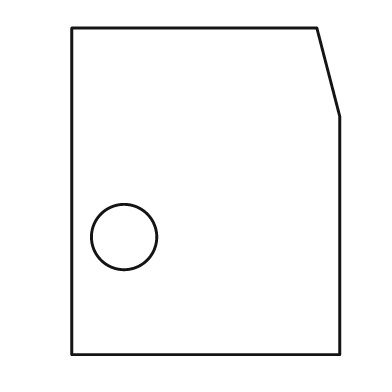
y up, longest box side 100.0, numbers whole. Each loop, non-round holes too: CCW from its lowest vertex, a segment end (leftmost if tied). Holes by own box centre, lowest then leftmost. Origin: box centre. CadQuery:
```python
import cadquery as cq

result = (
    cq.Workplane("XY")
    .moveTo(-41.0, -50.0)
    .lineTo(41.0, -50.0)
    .lineTo(41.0, 23.0)
    .lineTo(34.0, 50.0)
    .lineTo(-41.0, 50.0)
    .close()
    .moveTo(-25.0, -14.0)
    .circle(10.0)
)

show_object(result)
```